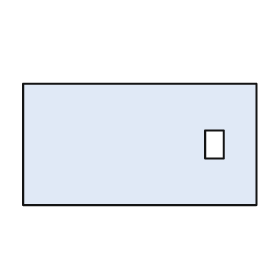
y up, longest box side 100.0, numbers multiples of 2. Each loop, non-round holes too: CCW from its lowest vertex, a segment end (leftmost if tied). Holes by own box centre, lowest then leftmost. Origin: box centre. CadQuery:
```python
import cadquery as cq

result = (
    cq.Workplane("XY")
    .moveTo(-50.0, -26.0)
    .lineTo(50.0, -26.0)
    .lineTo(50.0, 26.0)
    .lineTo(-50.0, 26.0)
    .close()
    .moveTo(28.0, -6.0)
    .lineTo(36.0, -6.0)
    .lineTo(36.0, 6.0)
    .lineTo(28.0, 6.0)
    .close()
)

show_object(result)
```